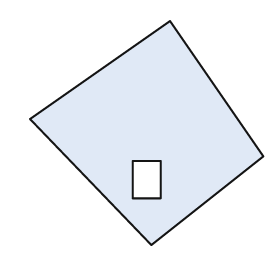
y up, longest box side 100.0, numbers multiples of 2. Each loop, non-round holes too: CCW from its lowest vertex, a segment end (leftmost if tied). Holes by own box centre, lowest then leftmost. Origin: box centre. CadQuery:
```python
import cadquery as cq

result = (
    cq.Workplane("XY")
    .moveTo(2.0, -48.0)
    .lineTo(50.0, -10.0)
    .lineTo(10.0, 48.0)
    .lineTo(-50.0, 6.0)
    .close()
    .moveTo(-6.0, -28.0)
    .lineTo(6.0, -28.0)
    .lineTo(6.0, -12.0)
    .lineTo(-6.0, -12.0)
    .close()
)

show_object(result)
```